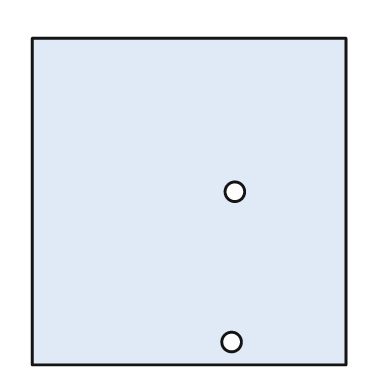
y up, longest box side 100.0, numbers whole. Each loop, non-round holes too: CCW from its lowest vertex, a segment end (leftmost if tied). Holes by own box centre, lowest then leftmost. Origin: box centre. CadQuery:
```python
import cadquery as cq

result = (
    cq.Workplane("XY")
    .moveTo(-48.0, -50.0)
    .lineTo(48.0, -50.0)
    .lineTo(48.0, 50.0)
    .lineTo(-48.0, 50.0)
    .close()
    .moveTo(13.0, -43.0)
    .circle(3.0)
    .moveTo(14.0, 3.0)
    .circle(3.0)
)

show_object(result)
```